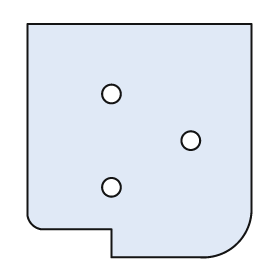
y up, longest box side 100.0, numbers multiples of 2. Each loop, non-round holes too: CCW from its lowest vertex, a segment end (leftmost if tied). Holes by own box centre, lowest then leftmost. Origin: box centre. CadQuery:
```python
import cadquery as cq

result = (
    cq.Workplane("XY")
    .moveTo(-12.0, -50.0)
    .lineTo(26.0, -50.0)
    .threePointArc((42.0, -44.0), (48.0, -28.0))
    .lineTo(48.0, 50.0)
    .lineTo(-48.0, 50.0)
    .lineTo(-48.0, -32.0)
    .threePointArc((-46.0, -36.0), (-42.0, -38.0))
    .lineTo(-12.0, -38.0)
    .close()
    .moveTo(-12.0, -20.0)
    .circle(4.0)
    .moveTo(22.0, 0.0)
    .circle(4.0)
    .moveTo(-12.0, 20.0)
    .circle(4.0)
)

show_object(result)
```